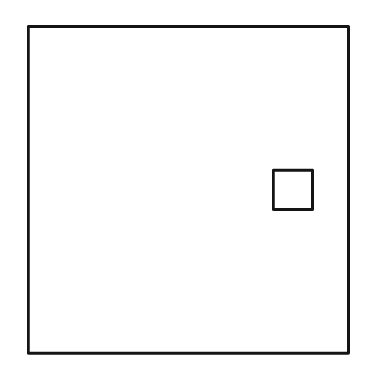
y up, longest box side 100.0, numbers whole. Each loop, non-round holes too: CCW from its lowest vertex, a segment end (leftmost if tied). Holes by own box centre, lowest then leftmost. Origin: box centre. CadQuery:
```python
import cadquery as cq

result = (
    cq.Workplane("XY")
    .moveTo(-49.0, -50.0)
    .lineTo(49.0, -50.0)
    .lineTo(49.0, 50.0)
    .lineTo(-49.0, 50.0)
    .close()
    .moveTo(26.0, -6.0)
    .lineTo(38.0, -6.0)
    .lineTo(38.0, 6.0)
    .lineTo(26.0, 6.0)
    .close()
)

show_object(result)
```